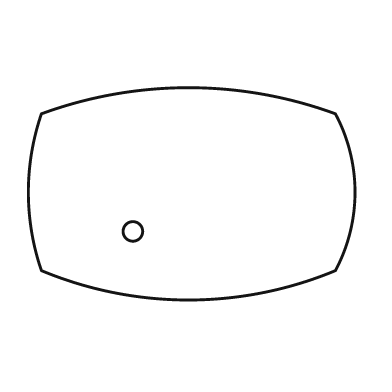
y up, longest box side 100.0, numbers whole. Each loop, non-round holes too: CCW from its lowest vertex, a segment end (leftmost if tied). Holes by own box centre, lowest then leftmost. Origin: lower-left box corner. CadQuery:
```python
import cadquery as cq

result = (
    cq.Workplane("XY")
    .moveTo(4.0, 9.0)
    .threePointArc((49.0, 0.0), (94.0, 9.0))
    .threePointArc((100.0, 33.0), (94.0, 57.0))
    .threePointArc((49.0, 65.0), (4.0, 57.0))
    .threePointArc((0.0, 33.0), (4.0, 9.0))
    .close()
    .moveTo(32.0, 21.0)
    .circle(3.0)
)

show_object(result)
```